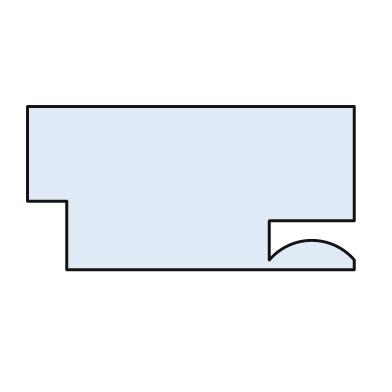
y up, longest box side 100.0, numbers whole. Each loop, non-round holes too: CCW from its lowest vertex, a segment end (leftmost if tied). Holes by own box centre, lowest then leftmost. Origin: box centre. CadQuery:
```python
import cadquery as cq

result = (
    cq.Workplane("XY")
    .moveTo(-38.0, -25.0)
    .lineTo(50.0, -25.0)
    .lineTo(50.0, -22.0)
    .threePointArc((37.0, -16.0), (24.0, -22.0))
    .lineTo(24.0, -10.0)
    .lineTo(50.0, -10.0)
    .lineTo(50.0, 25.0)
    .lineTo(-50.0, 25.0)
    .lineTo(-50.0, -4.0)
    .lineTo(-38.0, -4.0)
    .close()
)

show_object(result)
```